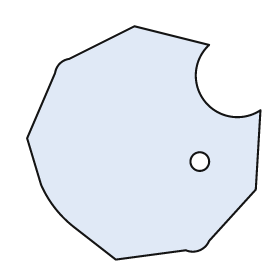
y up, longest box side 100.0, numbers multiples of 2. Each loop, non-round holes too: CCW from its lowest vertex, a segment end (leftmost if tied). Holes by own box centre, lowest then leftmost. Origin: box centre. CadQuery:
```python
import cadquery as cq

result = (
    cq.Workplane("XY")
    .moveTo(-12.0, -50.0)
    .lineTo(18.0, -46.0)
    .threePointArc((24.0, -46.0), (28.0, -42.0))
    .lineTo(48.0, -20.0)
    .lineTo(50.0, 14.0)
    .threePointArc((26.0, 18.0), (28.0, 42.0))
    .lineTo(-4.0, 50.0)
    .lineTo(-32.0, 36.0)
    .threePointArc((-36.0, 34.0), (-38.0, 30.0))
    .lineTo(-50.0, 2.0)
    .lineTo(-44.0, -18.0)
    .threePointArc((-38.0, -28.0), (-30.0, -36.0))
    .close()
    .moveTo(24.0, -8.0)
    .circle(4.0)
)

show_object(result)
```